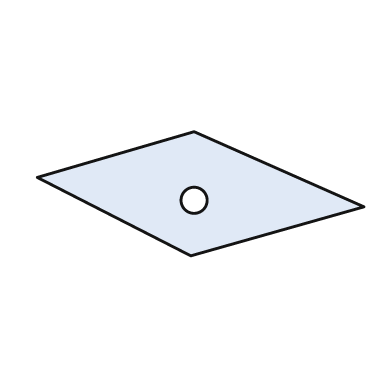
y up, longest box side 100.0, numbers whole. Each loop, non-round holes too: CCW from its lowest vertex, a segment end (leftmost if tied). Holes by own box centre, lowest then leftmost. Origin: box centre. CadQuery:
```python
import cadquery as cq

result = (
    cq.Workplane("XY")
    .moveTo(-3.0, -19.0)
    .lineTo(50.0, -4.0)
    .lineTo(-2.0, 19.0)
    .lineTo(-50.0, 5.0)
    .close()
    .moveTo(-2.0, -2.0)
    .circle(4.0)
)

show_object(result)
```